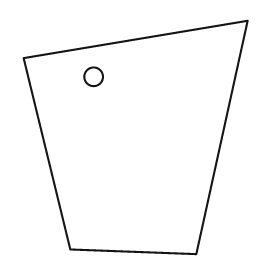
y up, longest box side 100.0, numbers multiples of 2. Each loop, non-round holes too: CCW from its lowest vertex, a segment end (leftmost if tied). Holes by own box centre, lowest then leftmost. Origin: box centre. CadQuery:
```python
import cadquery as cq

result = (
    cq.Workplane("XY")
    .moveTo(26.0, -50.0)
    .lineTo(48.0, 50.0)
    .lineTo(-48.0, 34.0)
    .lineTo(-28.0, -48.0)
    .close()
    .moveTo(-18.0, 26.0)
    .circle(4.0)
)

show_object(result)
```